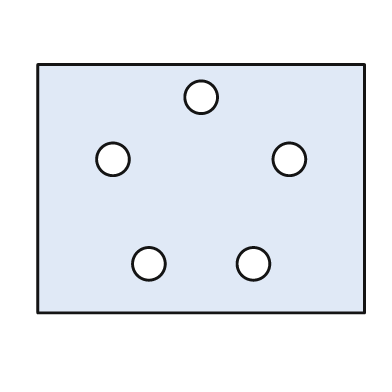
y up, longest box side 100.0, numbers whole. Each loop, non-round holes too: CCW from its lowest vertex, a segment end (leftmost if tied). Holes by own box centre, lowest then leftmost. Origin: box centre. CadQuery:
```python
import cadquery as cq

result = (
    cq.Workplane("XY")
    .moveTo(-50.0, -38.0)
    .lineTo(50.0, -38.0)
    .lineTo(50.0, 38.0)
    .lineTo(-50.0, 38.0)
    .close()
    .moveTo(-16.0, -23.0)
    .circle(5.0)
    .moveTo(16.0, -23.0)
    .circle(5.0)
    .moveTo(-27.0, 9.0)
    .circle(5.0)
    .moveTo(27.0, 9.0)
    .circle(5.0)
    .moveTo(0.0, 28.0)
    .circle(5.0)
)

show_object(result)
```